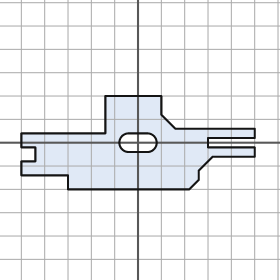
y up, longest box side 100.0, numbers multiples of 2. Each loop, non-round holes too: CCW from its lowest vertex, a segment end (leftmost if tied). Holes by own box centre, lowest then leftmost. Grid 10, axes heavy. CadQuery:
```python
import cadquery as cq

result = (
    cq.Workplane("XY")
    .moveTo(-30.0, -20.0)
    .lineTo(22.0, -20.0)
    .lineTo(26.0, -16.0)
    .lineTo(26.0, -12.0)
    .lineTo(32.0, -6.0)
    .lineTo(50.0, -6.0)
    .lineTo(50.0, -2.0)
    .lineTo(30.0, -2.0)
    .lineTo(30.0, 2.0)
    .lineTo(50.0, 2.0)
    .lineTo(50.0, 6.0)
    .lineTo(16.0, 6.0)
    .lineTo(10.0, 12.0)
    .lineTo(10.0, 20.0)
    .lineTo(-14.0, 20.0)
    .lineTo(-14.0, 4.0)
    .lineTo(-50.0, 4.0)
    .lineTo(-50.0, -2.0)
    .lineTo(-44.0, -2.0)
    .lineTo(-44.0, -8.0)
    .lineTo(-50.0, -8.0)
    .lineTo(-50.0, -14.0)
    .lineTo(-30.0, -14.0)
    .close()
    .moveTo(-4.0, -4.0)
    .lineTo(4.0, -4.0)
    .threePointArc((8.0, 0.0), (4.0, 4.0))
    .lineTo(-4.0, 4.0)
    .threePointArc((-8.0, 0.0), (-4.0, -4.0))
    .close()
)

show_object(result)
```